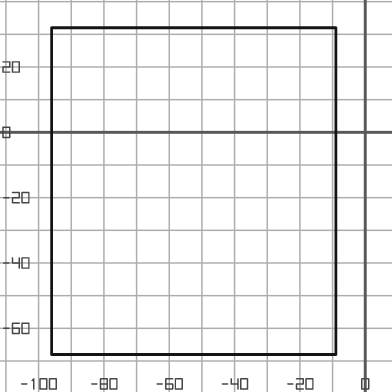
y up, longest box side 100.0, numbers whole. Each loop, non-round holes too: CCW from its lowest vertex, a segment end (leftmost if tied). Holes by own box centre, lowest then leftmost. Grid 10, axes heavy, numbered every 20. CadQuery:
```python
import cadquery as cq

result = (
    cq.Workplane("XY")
    .moveTo(-96.0, -68.0)
    .lineTo(-9.0, -68.0)
    .lineTo(-9.0, 32.0)
    .lineTo(-96.0, 32.0)
    .close()
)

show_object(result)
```